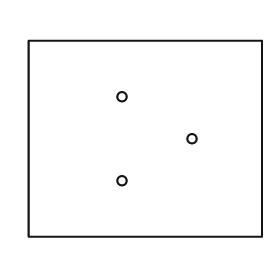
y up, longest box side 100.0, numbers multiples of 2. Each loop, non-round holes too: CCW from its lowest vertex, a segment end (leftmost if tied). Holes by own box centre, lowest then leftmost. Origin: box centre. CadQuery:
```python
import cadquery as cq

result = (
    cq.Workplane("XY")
    .moveTo(-50.0, -42.0)
    .lineTo(50.0, -42.0)
    .lineTo(50.0, 42.0)
    .lineTo(-50.0, 42.0)
    .close()
    .moveTo(-10.0, -18.0)
    .circle(2.0)
    .moveTo(20.0, 0.0)
    .circle(2.0)
    .moveTo(-10.0, 18.0)
    .circle(2.0)
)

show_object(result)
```